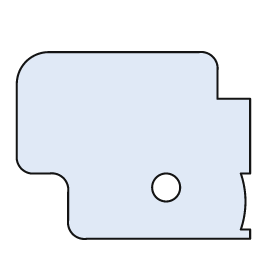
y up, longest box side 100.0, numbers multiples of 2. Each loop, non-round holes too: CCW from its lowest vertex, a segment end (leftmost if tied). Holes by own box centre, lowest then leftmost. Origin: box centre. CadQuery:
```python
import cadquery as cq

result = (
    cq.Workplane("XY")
    .moveTo(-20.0, -40.0)
    .lineTo(50.0, -40.0)
    .lineTo(50.0, -36.0)
    .lineTo(46.0, -36.0)
    .threePointArc((48.0, -24.0), (46.0, -12.0))
    .lineTo(50.0, -12.0)
    .lineTo(50.0, 20.0)
    .lineTo(36.0, 20.0)
    .lineTo(36.0, 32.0)
    .threePointArc((34.0, 38.0), (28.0, 40.0))
    .lineTo(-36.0, 40.0)
    .threePointArc((-46.0, 36.0), (-50.0, 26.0))
    .lineTo(-50.0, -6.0)
    .threePointArc((-48.0, -10.0), (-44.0, -12.0))
    .lineTo(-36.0, -12.0)
    .threePointArc((-30.0, -14.0), (-28.0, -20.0))
    .lineTo(-28.0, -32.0)
    .threePointArc((-26.0, -38.0), (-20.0, -40.0))
    .close()
    .moveTo(14.0, -18.0)
    .circle(6.0)
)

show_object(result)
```